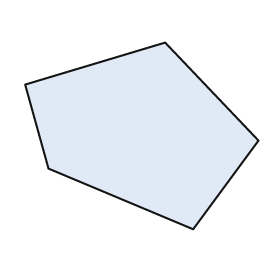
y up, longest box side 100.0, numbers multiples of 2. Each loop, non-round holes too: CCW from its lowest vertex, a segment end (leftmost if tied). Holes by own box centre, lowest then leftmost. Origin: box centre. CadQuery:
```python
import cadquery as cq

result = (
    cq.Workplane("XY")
    .moveTo(22.0, -40.0)
    .lineTo(50.0, -2.0)
    .lineTo(10.0, 40.0)
    .lineTo(-50.0, 22.0)
    .lineTo(-40.0, -14.0)
    .close()
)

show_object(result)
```